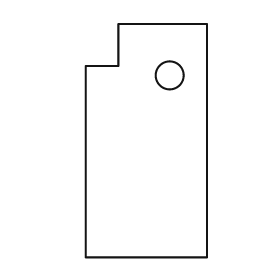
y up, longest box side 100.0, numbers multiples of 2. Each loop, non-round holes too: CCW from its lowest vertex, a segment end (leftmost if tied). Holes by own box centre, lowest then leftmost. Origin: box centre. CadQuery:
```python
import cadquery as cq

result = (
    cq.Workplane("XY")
    .moveTo(-26.0, -50.0)
    .lineTo(26.0, -50.0)
    .lineTo(26.0, 50.0)
    .lineTo(-12.0, 50.0)
    .lineTo(-12.0, 32.0)
    .lineTo(-26.0, 32.0)
    .close()
    .moveTo(10.0, 28.0)
    .circle(6.0)
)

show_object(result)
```